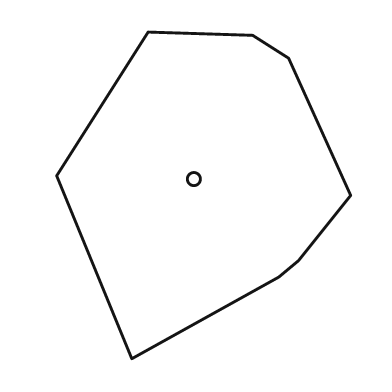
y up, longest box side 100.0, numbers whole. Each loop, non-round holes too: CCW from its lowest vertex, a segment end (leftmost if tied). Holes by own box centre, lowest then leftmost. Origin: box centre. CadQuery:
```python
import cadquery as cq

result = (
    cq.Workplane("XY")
    .moveTo(-22.0, -50.0)
    .lineTo(23.0, -25.0)
    .lineTo(29.0, -20.0)
    .lineTo(45.0, 0.0)
    .lineTo(26.0, 42.0)
    .lineTo(15.0, 49.0)
    .lineTo(-17.0, 50.0)
    .lineTo(-45.0, 6.0)
    .close()
    .moveTo(-3.0, 5.0)
    .circle(2.0)
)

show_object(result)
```